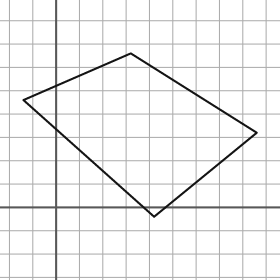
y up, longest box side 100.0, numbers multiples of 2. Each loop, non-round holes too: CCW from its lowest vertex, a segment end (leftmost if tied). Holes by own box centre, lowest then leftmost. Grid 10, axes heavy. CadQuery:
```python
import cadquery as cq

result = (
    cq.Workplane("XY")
    .moveTo(42.0, -4.0)
    .lineTo(86.0, 32.0)
    .lineTo(32.0, 66.0)
    .lineTo(-14.0, 46.0)
    .close()
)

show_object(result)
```